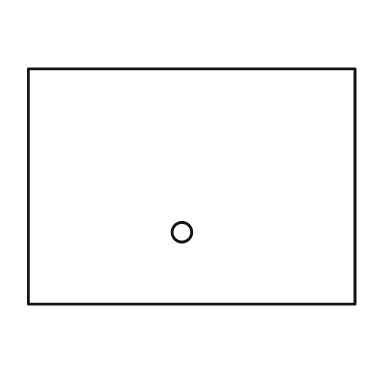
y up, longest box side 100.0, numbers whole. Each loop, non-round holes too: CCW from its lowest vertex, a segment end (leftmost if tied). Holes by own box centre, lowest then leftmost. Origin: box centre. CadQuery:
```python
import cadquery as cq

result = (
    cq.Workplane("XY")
    .moveTo(-50.0, -36.0)
    .lineTo(50.0, -36.0)
    .lineTo(50.0, 36.0)
    .lineTo(-50.0, 36.0)
    .close()
    .moveTo(-3.0, -14.0)
    .circle(3.0)
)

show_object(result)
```